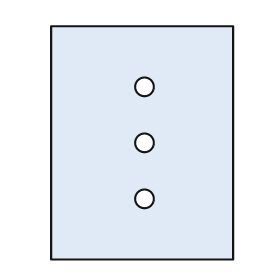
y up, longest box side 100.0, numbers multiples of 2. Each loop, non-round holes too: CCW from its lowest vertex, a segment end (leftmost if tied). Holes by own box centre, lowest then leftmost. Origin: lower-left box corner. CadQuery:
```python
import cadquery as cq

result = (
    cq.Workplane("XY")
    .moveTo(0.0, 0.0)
    .lineTo(78.0, 0.0)
    .lineTo(78.0, 100.0)
    .lineTo(0.0, 100.0)
    .close()
    .moveTo(40.0, 26.0)
    .circle(4.0)
    .moveTo(40.0, 50.0)
    .circle(4.0)
    .moveTo(40.0, 74.0)
    .circle(4.0)
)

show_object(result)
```